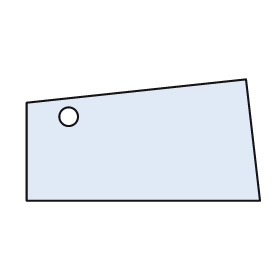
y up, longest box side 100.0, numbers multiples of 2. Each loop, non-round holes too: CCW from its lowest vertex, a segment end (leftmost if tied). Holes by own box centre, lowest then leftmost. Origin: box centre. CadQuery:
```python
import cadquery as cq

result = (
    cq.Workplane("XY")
    .moveTo(-50.0, -26.0)
    .lineTo(50.0, -26.0)
    .lineTo(44.0, 26.0)
    .lineTo(-50.0, 16.0)
    .close()
    .moveTo(-32.0, 10.0)
    .circle(4.0)
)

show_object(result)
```